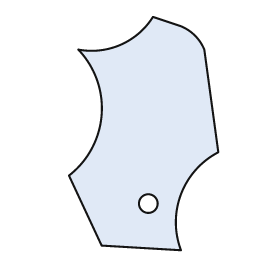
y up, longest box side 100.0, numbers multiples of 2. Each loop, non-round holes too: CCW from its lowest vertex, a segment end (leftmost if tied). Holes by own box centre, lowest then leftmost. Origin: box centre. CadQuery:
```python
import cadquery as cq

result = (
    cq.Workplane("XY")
    .moveTo(16.0, -50.0)
    .threePointArc((16.0, -26.0), (32.0, -8.0))
    .lineTo(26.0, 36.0)
    .threePointArc((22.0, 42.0), (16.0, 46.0))
    .lineTo(4.0, 50.0)
    .threePointArc((-10.0, 38.0), (-28.0, 36.0))
    .threePointArc((-18.0, 8.0), (-32.0, -18.0))
    .lineTo(-18.0, -48.0)
    .close()
    .moveTo(2.0, -30.0)
    .circle(4.0)
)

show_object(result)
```